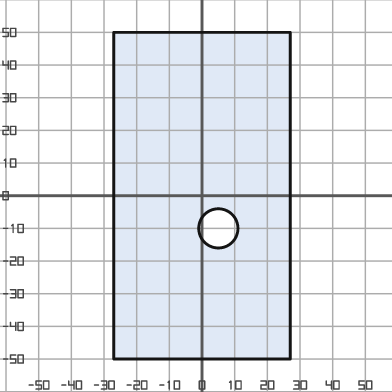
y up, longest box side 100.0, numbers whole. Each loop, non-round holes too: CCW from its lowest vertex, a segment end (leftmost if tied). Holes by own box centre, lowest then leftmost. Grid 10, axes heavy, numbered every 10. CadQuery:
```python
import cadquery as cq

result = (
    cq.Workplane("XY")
    .moveTo(-27.0, -50.0)
    .lineTo(27.0, -50.0)
    .lineTo(27.0, 50.0)
    .lineTo(-27.0, 50.0)
    .close()
    .moveTo(5.0, -10.0)
    .circle(6.0)
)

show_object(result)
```